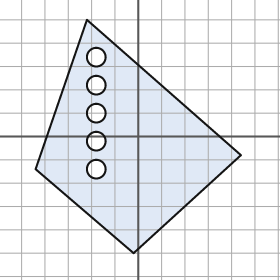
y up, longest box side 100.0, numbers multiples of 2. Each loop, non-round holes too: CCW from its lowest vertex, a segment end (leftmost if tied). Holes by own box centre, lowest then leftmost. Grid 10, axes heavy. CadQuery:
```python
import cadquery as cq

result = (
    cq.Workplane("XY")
    .moveTo(-2.0, -50.0)
    .lineTo(44.0, -8.0)
    .lineTo(-22.0, 50.0)
    .lineTo(-44.0, -14.0)
    .close()
    .moveTo(-18.0, -14.0)
    .circle(4.0)
    .moveTo(-18.0, -2.0)
    .circle(4.0)
    .moveTo(-18.0, 10.0)
    .circle(4.0)
    .moveTo(-18.0, 22.0)
    .circle(4.0)
    .moveTo(-18.0, 34.0)
    .circle(4.0)
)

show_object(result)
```